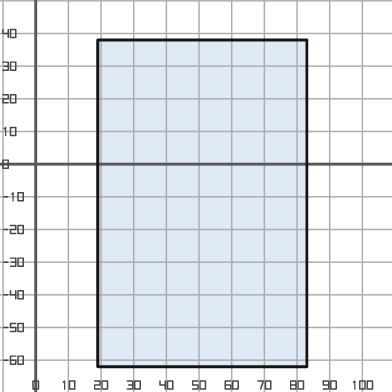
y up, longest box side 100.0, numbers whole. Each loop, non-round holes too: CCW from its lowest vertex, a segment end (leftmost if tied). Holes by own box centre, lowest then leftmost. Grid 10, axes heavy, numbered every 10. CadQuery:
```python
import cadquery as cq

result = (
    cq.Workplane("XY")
    .moveTo(19.0, -62.0)
    .lineTo(83.0, -62.0)
    .lineTo(83.0, 38.0)
    .lineTo(19.0, 38.0)
    .close()
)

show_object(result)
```